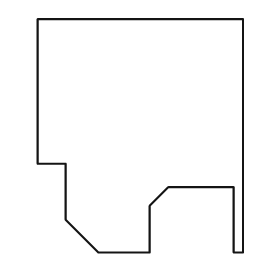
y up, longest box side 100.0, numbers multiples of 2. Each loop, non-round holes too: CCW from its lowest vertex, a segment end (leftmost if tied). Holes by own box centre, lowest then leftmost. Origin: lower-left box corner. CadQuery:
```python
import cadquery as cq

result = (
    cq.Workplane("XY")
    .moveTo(26.0, 0.0)
    .lineTo(48.0, 0.0)
    .lineTo(48.0, 20.0)
    .lineTo(56.0, 28.0)
    .lineTo(84.0, 28.0)
    .lineTo(84.0, 0.0)
    .lineTo(88.0, 0.0)
    .lineTo(88.0, 100.0)
    .lineTo(0.0, 100.0)
    .lineTo(0.0, 38.0)
    .lineTo(12.0, 38.0)
    .lineTo(12.0, 14.0)
    .close()
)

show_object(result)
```